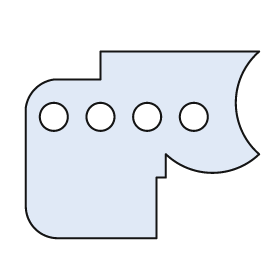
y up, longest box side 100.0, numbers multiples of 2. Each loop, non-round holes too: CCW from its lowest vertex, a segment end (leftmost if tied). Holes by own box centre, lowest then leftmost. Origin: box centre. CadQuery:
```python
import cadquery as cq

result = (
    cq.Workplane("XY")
    .moveTo(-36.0, -40.0)
    .lineTo(6.0, -40.0)
    .lineTo(6.0, -14.0)
    .lineTo(10.0, -14.0)
    .lineTo(10.0, -4.0)
    .threePointArc((30.0, -12.0), (50.0, -4.0))
    .threePointArc((40.0, 18.0), (50.0, 40.0))
    .lineTo(-18.0, 40.0)
    .lineTo(-18.0, 28.0)
    .lineTo(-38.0, 28.0)
    .threePointArc((-46.0, 24.0), (-50.0, 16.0))
    .lineTo(-50.0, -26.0)
    .threePointArc((-46.0, -36.0), (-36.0, -40.0))
    .close()
    .moveTo(-38.0, 12.0)
    .circle(6.0)
    .moveTo(-18.0, 12.0)
    .circle(6.0)
    .moveTo(2.0, 12.0)
    .circle(6.0)
    .moveTo(22.0, 12.0)
    .circle(6.0)
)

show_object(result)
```